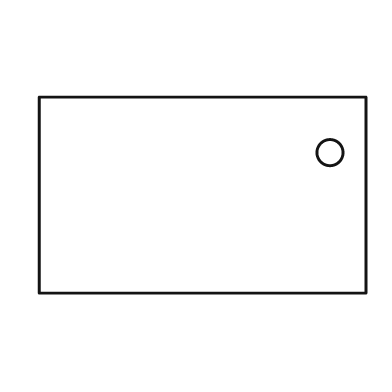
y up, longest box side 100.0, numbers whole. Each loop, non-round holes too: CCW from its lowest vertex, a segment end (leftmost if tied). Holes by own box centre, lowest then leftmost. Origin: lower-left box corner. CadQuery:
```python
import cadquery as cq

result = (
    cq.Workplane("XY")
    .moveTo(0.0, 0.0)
    .lineTo(100.0, 0.0)
    .lineTo(100.0, 60.0)
    .lineTo(0.0, 60.0)
    .close()
    .moveTo(89.0, 43.0)
    .circle(4.0)
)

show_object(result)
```